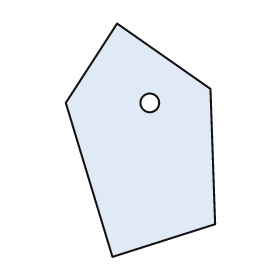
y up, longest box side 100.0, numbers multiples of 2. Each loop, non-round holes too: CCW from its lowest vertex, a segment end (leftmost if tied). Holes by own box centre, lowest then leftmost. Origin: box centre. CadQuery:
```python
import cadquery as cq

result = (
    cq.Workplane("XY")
    .moveTo(-12.0, -50.0)
    .lineTo(32.0, -36.0)
    .lineTo(30.0, 22.0)
    .lineTo(-10.0, 50.0)
    .lineTo(-32.0, 16.0)
    .close()
    .moveTo(4.0, 16.0)
    .circle(4.0)
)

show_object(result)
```